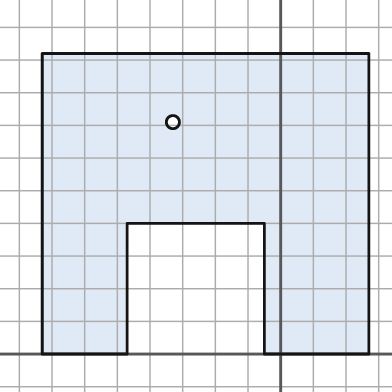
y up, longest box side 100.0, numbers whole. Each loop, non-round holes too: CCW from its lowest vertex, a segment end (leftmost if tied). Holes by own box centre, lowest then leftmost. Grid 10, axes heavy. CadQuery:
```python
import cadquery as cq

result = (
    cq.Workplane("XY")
    .moveTo(-73.0, 0.0)
    .lineTo(-47.0, 0.0)
    .lineTo(-47.0, 40.0)
    .lineTo(-5.0, 40.0)
    .lineTo(-5.0, 0.0)
    .lineTo(27.0, 0.0)
    .lineTo(27.0, 92.0)
    .lineTo(-73.0, 92.0)
    .close()
    .moveTo(-33.0, 71.0)
    .circle(2.0)
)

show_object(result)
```